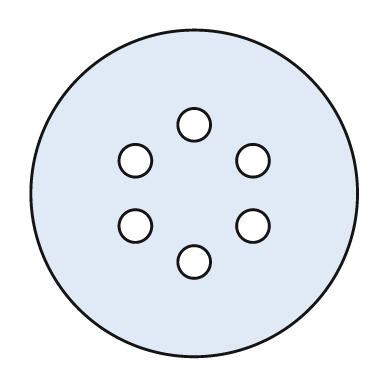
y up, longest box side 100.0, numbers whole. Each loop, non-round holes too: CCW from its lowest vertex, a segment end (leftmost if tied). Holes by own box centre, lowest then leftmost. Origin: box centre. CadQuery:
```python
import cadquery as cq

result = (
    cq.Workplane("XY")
    .moveTo(0.0, 0.0)
    .circle(50.0)
    .moveTo(0.0, -21.0)
    .circle(5.0)
    .moveTo(-18.0, -10.0)
    .circle(5.0)
    .moveTo(18.0, -10.0)
    .circle(5.0)
    .moveTo(-18.0, 10.0)
    .circle(5.0)
    .moveTo(18.0, 10.0)
    .circle(5.0)
    .moveTo(0.0, 21.0)
    .circle(5.0)
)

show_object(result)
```